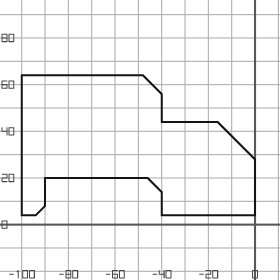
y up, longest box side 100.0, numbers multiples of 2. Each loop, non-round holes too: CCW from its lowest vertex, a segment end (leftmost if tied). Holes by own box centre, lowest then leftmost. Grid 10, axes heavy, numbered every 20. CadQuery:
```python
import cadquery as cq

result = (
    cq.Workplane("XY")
    .moveTo(-100.0, 4.0)
    .lineTo(-94.0, 4.0)
    .lineTo(-90.0, 8.0)
    .lineTo(-90.0, 20.0)
    .lineTo(-46.0, 20.0)
    .lineTo(-40.0, 14.0)
    .lineTo(-40.0, 4.0)
    .lineTo(0.0, 4.0)
    .lineTo(0.0, 28.0)
    .lineTo(-16.0, 44.0)
    .lineTo(-40.0, 44.0)
    .lineTo(-40.0, 56.0)
    .lineTo(-48.0, 64.0)
    .lineTo(-100.0, 64.0)
    .close()
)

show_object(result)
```